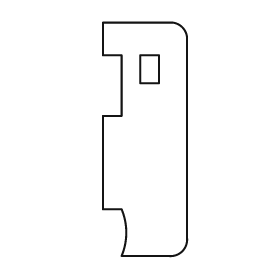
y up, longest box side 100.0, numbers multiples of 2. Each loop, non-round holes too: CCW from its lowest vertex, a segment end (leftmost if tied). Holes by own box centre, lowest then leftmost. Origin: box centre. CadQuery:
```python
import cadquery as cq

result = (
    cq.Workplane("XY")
    .moveTo(-10.0, -50.0)
    .lineTo(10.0, -50.0)
    .threePointArc((16.0, -48.0), (18.0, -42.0))
    .lineTo(18.0, 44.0)
    .threePointArc((16.0, 48.0), (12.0, 50.0))
    .lineTo(-18.0, 50.0)
    .lineTo(-18.0, 36.0)
    .lineTo(-10.0, 36.0)
    .lineTo(-10.0, 10.0)
    .lineTo(-18.0, 10.0)
    .lineTo(-18.0, -30.0)
    .lineTo(-10.0, -30.0)
    .threePointArc((-8.0, -40.0), (-10.0, -50.0))
    .close()
    .moveTo(-2.0, 24.0)
    .lineTo(6.0, 24.0)
    .lineTo(6.0, 36.0)
    .lineTo(-2.0, 36.0)
    .close()
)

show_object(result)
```